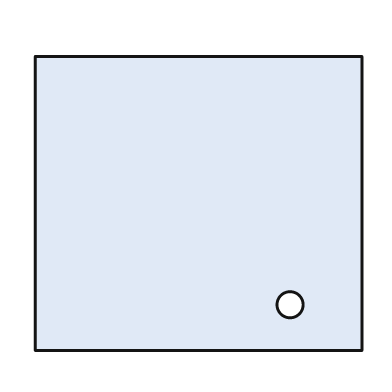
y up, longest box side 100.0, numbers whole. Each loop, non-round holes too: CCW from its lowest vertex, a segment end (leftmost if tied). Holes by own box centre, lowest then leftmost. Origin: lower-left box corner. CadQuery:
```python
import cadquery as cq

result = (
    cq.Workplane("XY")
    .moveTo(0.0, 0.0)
    .lineTo(100.0, 0.0)
    .lineTo(100.0, 90.0)
    .lineTo(0.0, 90.0)
    .close()
    .moveTo(78.0, 14.0)
    .circle(4.0)
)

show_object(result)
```